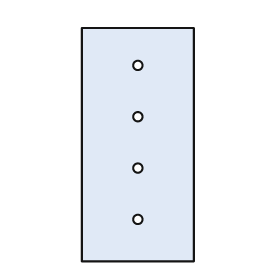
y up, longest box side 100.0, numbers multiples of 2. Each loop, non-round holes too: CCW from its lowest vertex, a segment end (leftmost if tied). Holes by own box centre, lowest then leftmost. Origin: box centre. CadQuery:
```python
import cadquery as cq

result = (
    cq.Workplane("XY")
    .moveTo(-24.0, -50.0)
    .lineTo(24.0, -50.0)
    .lineTo(24.0, 50.0)
    .lineTo(-24.0, 50.0)
    .close()
    .moveTo(0.0, -32.0)
    .circle(2.0)
    .moveTo(0.0, -10.0)
    .circle(2.0)
    .moveTo(0.0, 12.0)
    .circle(2.0)
    .moveTo(0.0, 34.0)
    .circle(2.0)
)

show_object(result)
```